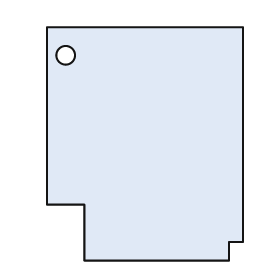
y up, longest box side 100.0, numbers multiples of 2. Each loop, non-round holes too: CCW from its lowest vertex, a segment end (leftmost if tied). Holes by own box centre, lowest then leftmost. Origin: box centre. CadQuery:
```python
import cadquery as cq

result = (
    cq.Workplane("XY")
    .moveTo(-26.0, -50.0)
    .lineTo(36.0, -50.0)
    .lineTo(36.0, -42.0)
    .lineTo(42.0, -42.0)
    .lineTo(42.0, 50.0)
    .lineTo(-42.0, 50.0)
    .lineTo(-42.0, -26.0)
    .lineTo(-26.0, -26.0)
    .close()
    .moveTo(-34.0, 38.0)
    .circle(4.0)
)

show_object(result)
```